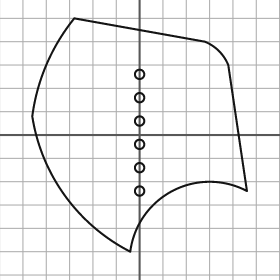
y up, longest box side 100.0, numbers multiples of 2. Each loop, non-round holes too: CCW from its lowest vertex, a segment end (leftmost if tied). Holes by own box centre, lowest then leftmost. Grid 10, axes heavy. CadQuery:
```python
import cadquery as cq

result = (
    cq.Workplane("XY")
    .moveTo(-4.0, -50.0)
    .threePointArc((14.0, -24.0), (46.0, -24.0))
    .lineTo(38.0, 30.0)
    .threePointArc((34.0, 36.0), (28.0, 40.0))
    .lineTo(-28.0, 50.0)
    .threePointArc((-40.0, 30.0), (-46.0, 8.0))
    .threePointArc((-32.0, -26.0), (-4.0, -50.0))
    .close()
    .moveTo(0.0, -24.0)
    .circle(2.0)
    .moveTo(0.0, -14.0)
    .circle(2.0)
    .moveTo(0.0, -4.0)
    .circle(2.0)
    .moveTo(0.0, 6.0)
    .circle(2.0)
    .moveTo(0.0, 16.0)
    .circle(2.0)
    .moveTo(0.0, 26.0)
    .circle(2.0)
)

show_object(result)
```